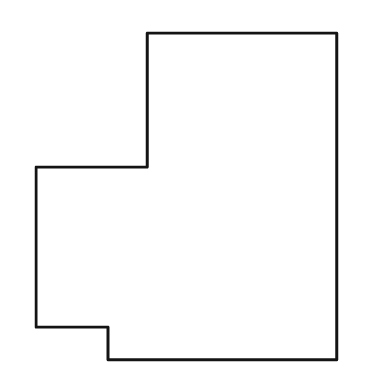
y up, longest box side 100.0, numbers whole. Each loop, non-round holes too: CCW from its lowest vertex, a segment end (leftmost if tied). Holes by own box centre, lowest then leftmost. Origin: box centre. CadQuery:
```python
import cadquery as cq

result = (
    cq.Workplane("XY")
    .moveTo(-24.0, -50.0)
    .lineTo(46.0, -50.0)
    .lineTo(46.0, 50.0)
    .lineTo(-12.0, 50.0)
    .lineTo(-12.0, 9.0)
    .lineTo(-46.0, 9.0)
    .lineTo(-46.0, -40.0)
    .lineTo(-24.0, -40.0)
    .close()
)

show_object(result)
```